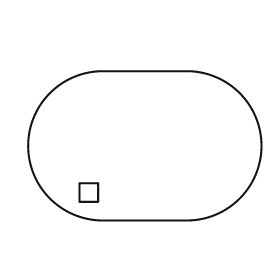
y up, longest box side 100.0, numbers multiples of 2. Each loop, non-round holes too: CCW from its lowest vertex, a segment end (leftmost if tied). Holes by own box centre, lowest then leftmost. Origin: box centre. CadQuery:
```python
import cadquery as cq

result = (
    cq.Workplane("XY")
    .moveTo(-18.0, -32.0)
    .lineTo(18.0, -32.0)
    .threePointArc((50.0, 0.0), (18.0, 32.0))
    .lineTo(-18.0, 32.0)
    .threePointArc((-50.0, 0.0), (-18.0, -32.0))
    .close()
    .moveTo(-28.0, -24.0)
    .lineTo(-20.0, -24.0)
    .lineTo(-20.0, -16.0)
    .lineTo(-28.0, -16.0)
    .close()
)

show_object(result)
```